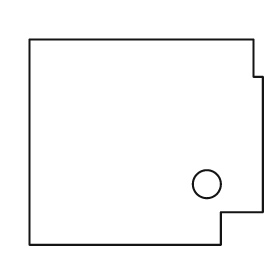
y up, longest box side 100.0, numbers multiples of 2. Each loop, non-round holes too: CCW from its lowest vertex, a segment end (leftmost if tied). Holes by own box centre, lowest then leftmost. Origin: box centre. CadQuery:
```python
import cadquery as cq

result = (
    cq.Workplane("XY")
    .moveTo(-50.0, -44.0)
    .lineTo(32.0, -44.0)
    .lineTo(32.0, -30.0)
    .lineTo(50.0, -30.0)
    .lineTo(50.0, 28.0)
    .lineTo(46.0, 28.0)
    .lineTo(46.0, 44.0)
    .lineTo(-50.0, 44.0)
    .close()
    .moveTo(26.0, -18.0)
    .circle(6.0)
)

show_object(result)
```